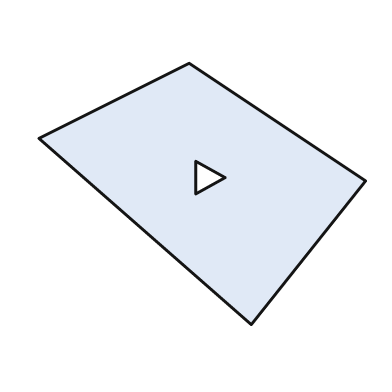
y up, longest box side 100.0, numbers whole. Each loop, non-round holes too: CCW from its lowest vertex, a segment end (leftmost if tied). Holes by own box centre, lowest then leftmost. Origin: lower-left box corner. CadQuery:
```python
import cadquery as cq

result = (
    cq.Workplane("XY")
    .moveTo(65.0, 0.0)
    .lineTo(100.0, 44.0)
    .lineTo(46.0, 80.0)
    .lineTo(0.0, 57.0)
    .close()
    .moveTo(48.0, 40.0)
    .lineTo(57.0, 45.0)
    .lineTo(48.0, 50.0)
    .close()
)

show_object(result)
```